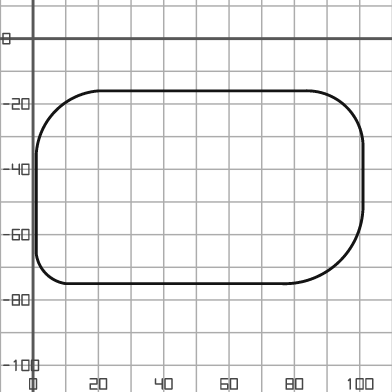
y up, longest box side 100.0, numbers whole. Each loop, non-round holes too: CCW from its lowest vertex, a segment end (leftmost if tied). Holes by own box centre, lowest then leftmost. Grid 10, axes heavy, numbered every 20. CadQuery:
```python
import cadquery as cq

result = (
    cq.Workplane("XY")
    .moveTo(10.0, -75.0)
    .lineTo(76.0, -75.0)
    .threePointArc((94.0, -68.0), (101.0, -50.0))
    .lineTo(101.0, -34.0)
    .threePointArc((96.0, -21.0), (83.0, -16.0))
    .lineTo(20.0, -16.0)
    .threePointArc((7.0, -22.0), (1.0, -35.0))
    .lineTo(1.0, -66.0)
    .threePointArc((4.0, -72.0), (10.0, -75.0))
    .close()
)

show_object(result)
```